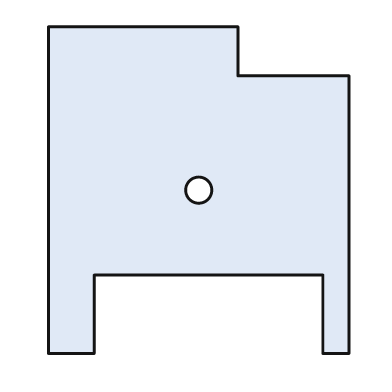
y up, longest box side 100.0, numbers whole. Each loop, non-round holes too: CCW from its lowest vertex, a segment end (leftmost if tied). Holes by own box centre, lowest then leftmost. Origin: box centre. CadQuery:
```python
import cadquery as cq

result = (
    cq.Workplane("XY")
    .moveTo(-46.0, -50.0)
    .lineTo(-32.0, -50.0)
    .lineTo(-32.0, -26.0)
    .lineTo(38.0, -26.0)
    .lineTo(38.0, -50.0)
    .lineTo(46.0, -50.0)
    .lineTo(46.0, 35.0)
    .lineTo(12.0, 35.0)
    .lineTo(12.0, 50.0)
    .lineTo(-46.0, 50.0)
    .close()
    .moveTo(0.0, 0.0)
    .circle(4.0)
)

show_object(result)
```